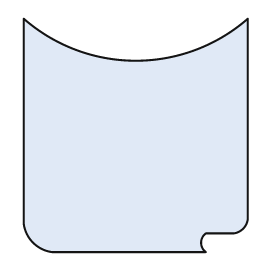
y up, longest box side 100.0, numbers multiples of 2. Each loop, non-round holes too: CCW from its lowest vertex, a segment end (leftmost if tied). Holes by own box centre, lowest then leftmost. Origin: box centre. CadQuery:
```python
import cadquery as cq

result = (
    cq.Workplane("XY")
    .moveTo(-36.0, -50.0)
    .lineTo(30.0, -50.0)
    .threePointArc((28.0, -46.0), (30.0, -42.0))
    .lineTo(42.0, -42.0)
    .threePointArc((46.0, -40.0), (48.0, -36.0))
    .lineTo(48.0, 50.0)
    .threePointArc((0.0, 32.0), (-48.0, 50.0))
    .lineTo(-48.0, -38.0)
    .threePointArc((-44.0, -46.0), (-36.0, -50.0))
    .close()
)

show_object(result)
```